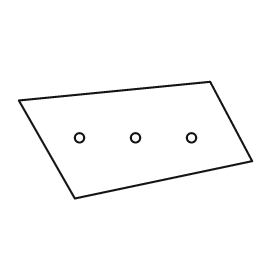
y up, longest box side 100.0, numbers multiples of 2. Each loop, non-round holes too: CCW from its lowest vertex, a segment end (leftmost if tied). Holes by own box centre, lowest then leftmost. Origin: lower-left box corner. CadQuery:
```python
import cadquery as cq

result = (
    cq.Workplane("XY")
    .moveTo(24.0, 0.0)
    .lineTo(100.0, 16.0)
    .lineTo(82.0, 50.0)
    .lineTo(0.0, 42.0)
    .close()
    .moveTo(26.0, 26.0)
    .circle(2.0)
    .moveTo(50.0, 26.0)
    .circle(2.0)
    .moveTo(74.0, 26.0)
    .circle(2.0)
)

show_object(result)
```